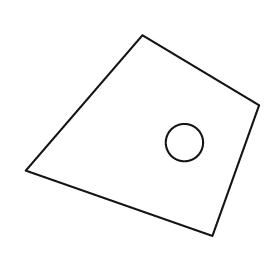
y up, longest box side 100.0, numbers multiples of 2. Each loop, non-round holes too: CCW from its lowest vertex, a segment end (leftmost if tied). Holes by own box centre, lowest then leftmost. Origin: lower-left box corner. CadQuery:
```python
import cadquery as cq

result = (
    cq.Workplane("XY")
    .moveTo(80.0, 0.0)
    .lineTo(100.0, 56.0)
    .lineTo(50.0, 86.0)
    .lineTo(0.0, 28.0)
    .close()
    .moveTo(68.0, 40.0)
    .circle(8.0)
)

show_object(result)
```